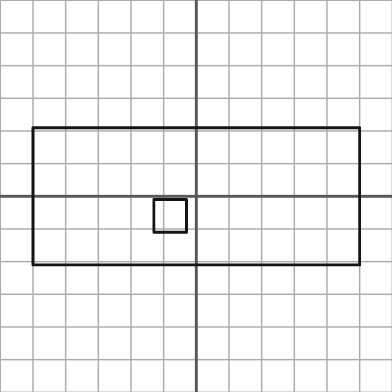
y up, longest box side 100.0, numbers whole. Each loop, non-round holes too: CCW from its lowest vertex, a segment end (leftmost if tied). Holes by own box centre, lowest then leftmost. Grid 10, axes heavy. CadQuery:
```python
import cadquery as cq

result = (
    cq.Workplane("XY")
    .moveTo(-50.0, -21.0)
    .lineTo(50.0, -21.0)
    .lineTo(50.0, 21.0)
    .lineTo(-50.0, 21.0)
    .close()
    .moveTo(-13.0, -11.0)
    .lineTo(-3.0, -11.0)
    .lineTo(-3.0, -1.0)
    .lineTo(-13.0, -1.0)
    .close()
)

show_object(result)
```